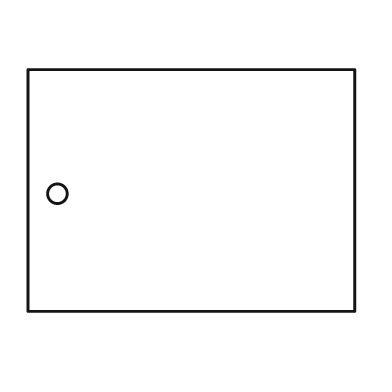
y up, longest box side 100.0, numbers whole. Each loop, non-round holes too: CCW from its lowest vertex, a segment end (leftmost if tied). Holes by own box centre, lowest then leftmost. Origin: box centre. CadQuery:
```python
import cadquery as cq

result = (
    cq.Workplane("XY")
    .moveTo(-50.0, -37.0)
    .lineTo(50.0, -37.0)
    .lineTo(50.0, 37.0)
    .lineTo(-50.0, 37.0)
    .close()
    .moveTo(-41.0, -1.0)
    .circle(3.0)
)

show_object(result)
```